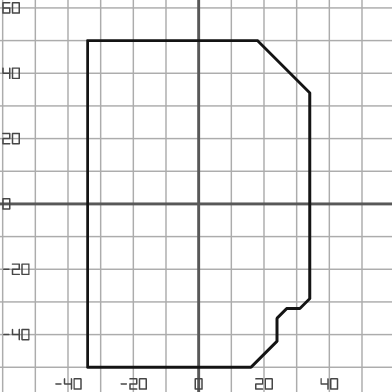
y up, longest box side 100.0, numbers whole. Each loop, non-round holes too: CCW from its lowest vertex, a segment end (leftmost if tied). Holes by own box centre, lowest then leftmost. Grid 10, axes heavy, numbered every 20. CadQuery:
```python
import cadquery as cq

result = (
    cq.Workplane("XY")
    .moveTo(-34.0, -50.0)
    .lineTo(16.0, -50.0)
    .lineTo(24.0, -42.0)
    .lineTo(24.0, -35.0)
    .lineTo(27.0, -32.0)
    .lineTo(31.0, -32.0)
    .lineTo(34.0, -29.0)
    .lineTo(34.0, 34.0)
    .lineTo(18.0, 50.0)
    .lineTo(-34.0, 50.0)
    .close()
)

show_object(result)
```